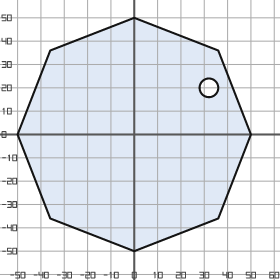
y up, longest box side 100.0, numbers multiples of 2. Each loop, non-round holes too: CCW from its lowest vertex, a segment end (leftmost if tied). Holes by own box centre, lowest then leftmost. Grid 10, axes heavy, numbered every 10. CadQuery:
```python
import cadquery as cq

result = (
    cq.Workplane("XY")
    .moveTo(0.0, -50.0)
    .lineTo(36.0, -36.0)
    .lineTo(50.0, 0.0)
    .lineTo(36.0, 36.0)
    .lineTo(0.0, 50.0)
    .lineTo(-36.0, 36.0)
    .lineTo(-50.0, 0.0)
    .lineTo(-36.0, -36.0)
    .close()
    .moveTo(32.0, 20.0)
    .circle(4.0)
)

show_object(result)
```